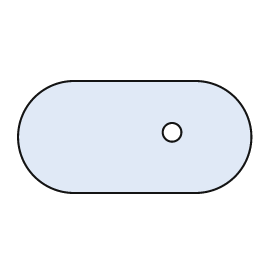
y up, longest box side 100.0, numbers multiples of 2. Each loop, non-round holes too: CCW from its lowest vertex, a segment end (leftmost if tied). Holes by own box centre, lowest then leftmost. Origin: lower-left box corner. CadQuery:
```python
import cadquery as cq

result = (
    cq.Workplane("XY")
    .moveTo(24.0, 0.0)
    .lineTo(76.0, 0.0)
    .threePointArc((100.0, 24.0), (76.0, 48.0))
    .lineTo(24.0, 48.0)
    .threePointArc((0.0, 24.0), (24.0, 0.0))
    .close()
    .moveTo(66.0, 26.0)
    .circle(4.0)
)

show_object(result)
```